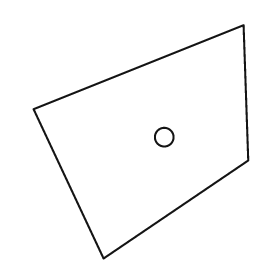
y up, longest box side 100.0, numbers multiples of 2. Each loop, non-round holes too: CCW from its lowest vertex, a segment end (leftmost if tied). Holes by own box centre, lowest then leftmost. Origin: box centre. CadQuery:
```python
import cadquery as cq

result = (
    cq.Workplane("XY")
    .moveTo(-16.0, -50.0)
    .lineTo(46.0, -8.0)
    .lineTo(44.0, 50.0)
    .lineTo(-46.0, 14.0)
    .close()
    .moveTo(10.0, 2.0)
    .circle(4.0)
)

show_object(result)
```